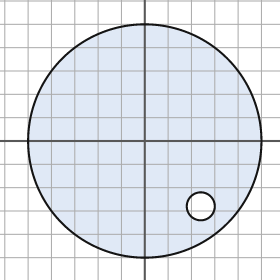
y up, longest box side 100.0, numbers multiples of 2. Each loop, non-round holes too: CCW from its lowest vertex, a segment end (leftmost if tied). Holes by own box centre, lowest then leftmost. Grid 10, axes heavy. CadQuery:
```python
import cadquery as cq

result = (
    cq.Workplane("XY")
    .moveTo(0.0, 0.0)
    .circle(50.0)
    .moveTo(24.0, -28.0)
    .circle(6.0)
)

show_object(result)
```